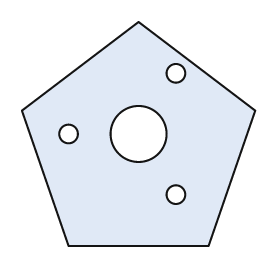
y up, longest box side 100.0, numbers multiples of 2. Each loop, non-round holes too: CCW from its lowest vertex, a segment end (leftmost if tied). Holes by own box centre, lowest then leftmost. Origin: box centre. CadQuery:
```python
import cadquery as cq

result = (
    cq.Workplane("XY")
    .moveTo(-30.0, -48.0)
    .lineTo(30.0, -48.0)
    .lineTo(50.0, 10.0)
    .lineTo(0.0, 48.0)
    .lineTo(-50.0, 10.0)
    .close()
    .moveTo(16.0, -26.0)
    .circle(4.0)
    .moveTo(-30.0, 0.0)
    .circle(4.0)
    .moveTo(0.0, 0.0)
    .circle(12.0)
    .moveTo(16.0, 26.0)
    .circle(4.0)
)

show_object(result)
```